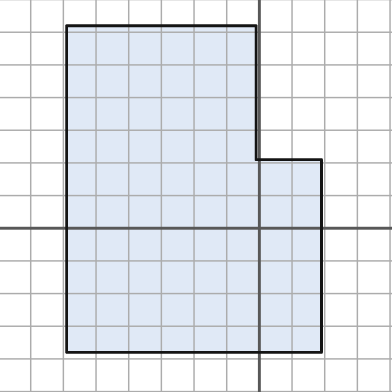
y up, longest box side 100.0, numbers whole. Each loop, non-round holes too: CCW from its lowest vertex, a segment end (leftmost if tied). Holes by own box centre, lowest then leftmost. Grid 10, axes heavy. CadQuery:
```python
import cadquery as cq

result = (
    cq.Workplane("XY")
    .moveTo(-59.0, -38.0)
    .lineTo(19.0, -38.0)
    .lineTo(19.0, 21.0)
    .lineTo(-1.0, 21.0)
    .lineTo(-1.0, 62.0)
    .lineTo(-59.0, 62.0)
    .close()
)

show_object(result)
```